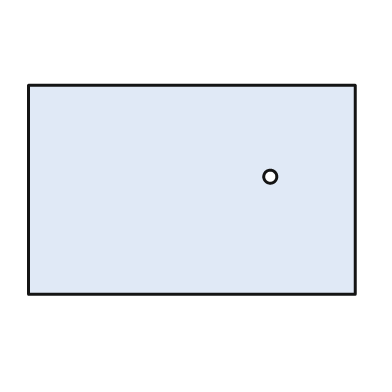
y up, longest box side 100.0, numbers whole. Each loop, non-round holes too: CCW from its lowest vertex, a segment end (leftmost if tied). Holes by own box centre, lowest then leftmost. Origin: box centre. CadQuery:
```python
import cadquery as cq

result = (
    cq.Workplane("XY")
    .moveTo(-50.0, -32.0)
    .lineTo(50.0, -32.0)
    .lineTo(50.0, 32.0)
    .lineTo(-50.0, 32.0)
    .close()
    .moveTo(24.0, 4.0)
    .circle(2.0)
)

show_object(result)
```